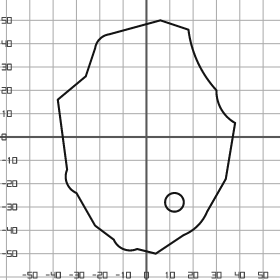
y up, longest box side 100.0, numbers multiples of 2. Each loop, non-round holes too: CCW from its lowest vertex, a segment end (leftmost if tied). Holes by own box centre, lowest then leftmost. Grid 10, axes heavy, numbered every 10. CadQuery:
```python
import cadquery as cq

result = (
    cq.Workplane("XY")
    .moveTo(4.0, -50.0)
    .lineTo(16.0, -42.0)
    .threePointArc((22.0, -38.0), (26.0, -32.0))
    .lineTo(34.0, -18.0)
    .lineTo(38.0, 6.0)
    .threePointArc((32.0, 12.0), (30.0, 20.0))
    .threePointArc((22.0, 32.0), (18.0, 46.0))
    .lineTo(6.0, 50.0)
    .lineTo(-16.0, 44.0)
    .threePointArc((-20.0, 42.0), (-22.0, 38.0))
    .lineTo(-26.0, 26.0)
    .lineTo(-38.0, 16.0)
    .lineTo(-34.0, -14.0)
    .threePointArc((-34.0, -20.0), (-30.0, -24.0))
    .lineTo(-22.0, -38.0)
    .lineTo(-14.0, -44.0)
    .threePointArc((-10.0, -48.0), (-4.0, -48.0))
    .close()
    .moveTo(12.0, -28.0)
    .circle(4.0)
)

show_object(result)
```